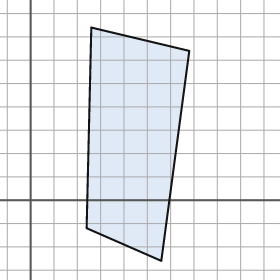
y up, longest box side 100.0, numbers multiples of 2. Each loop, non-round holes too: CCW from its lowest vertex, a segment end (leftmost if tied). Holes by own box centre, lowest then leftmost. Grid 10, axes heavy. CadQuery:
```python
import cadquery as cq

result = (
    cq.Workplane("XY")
    .moveTo(56.0, -26.0)
    .lineTo(68.0, 64.0)
    .lineTo(26.0, 74.0)
    .lineTo(24.0, -12.0)
    .close()
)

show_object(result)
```